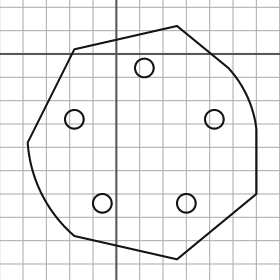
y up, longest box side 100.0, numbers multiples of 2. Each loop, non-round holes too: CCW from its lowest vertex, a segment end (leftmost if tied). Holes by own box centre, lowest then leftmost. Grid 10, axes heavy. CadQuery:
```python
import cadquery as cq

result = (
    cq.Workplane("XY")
    .moveTo(26.0, -88.0)
    .lineTo(60.0, -60.0)
    .lineTo(60.0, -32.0)
    .threePointArc((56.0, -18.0), (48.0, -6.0))
    .lineTo(26.0, 12.0)
    .lineTo(-18.0, 2.0)
    .lineTo(-38.0, -38.0)
    .threePointArc((-32.0, -60.0), (-18.0, -78.0))
    .close()
    .moveTo(-6.0, -64.0)
    .circle(4.0)
    .moveTo(30.0, -64.0)
    .circle(4.0)
    .moveTo(-18.0, -28.0)
    .circle(4.0)
    .moveTo(42.0, -28.0)
    .circle(4.0)
    .moveTo(12.0, -6.0)
    .circle(4.0)
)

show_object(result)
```